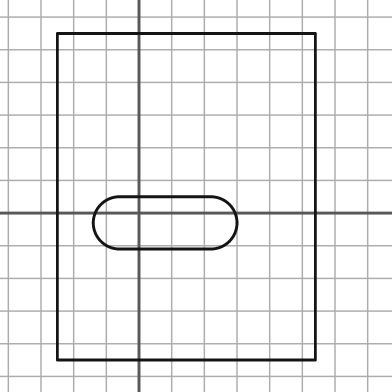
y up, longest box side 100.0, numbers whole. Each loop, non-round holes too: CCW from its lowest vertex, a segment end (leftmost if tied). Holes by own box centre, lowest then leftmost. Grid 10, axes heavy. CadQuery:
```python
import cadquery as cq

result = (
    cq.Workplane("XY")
    .moveTo(-25.0, -45.0)
    .lineTo(54.0, -45.0)
    .lineTo(54.0, 55.0)
    .lineTo(-25.0, 55.0)
    .close()
    .moveTo(-6.0, -11.0)
    .lineTo(22.0, -11.0)
    .threePointArc((30.0, -3.0), (22.0, 5.0))
    .lineTo(-6.0, 5.0)
    .threePointArc((-14.0, -3.0), (-6.0, -11.0))
    .close()
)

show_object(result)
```